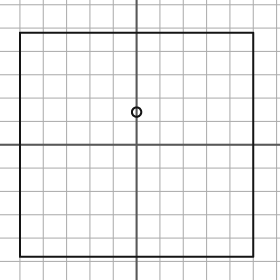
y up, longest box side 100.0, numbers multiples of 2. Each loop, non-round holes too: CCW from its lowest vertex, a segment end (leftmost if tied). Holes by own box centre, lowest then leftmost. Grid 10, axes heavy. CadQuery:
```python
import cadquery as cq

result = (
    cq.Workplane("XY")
    .moveTo(-50.0, -48.0)
    .lineTo(50.0, -48.0)
    .lineTo(50.0, 48.0)
    .lineTo(-50.0, 48.0)
    .close()
    .moveTo(0.0, 14.0)
    .circle(2.0)
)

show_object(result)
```